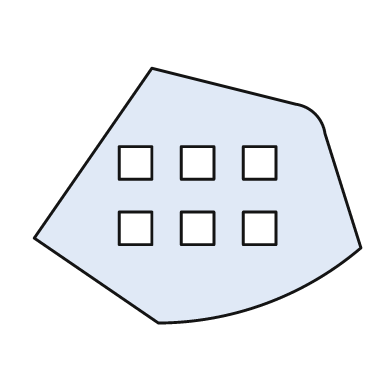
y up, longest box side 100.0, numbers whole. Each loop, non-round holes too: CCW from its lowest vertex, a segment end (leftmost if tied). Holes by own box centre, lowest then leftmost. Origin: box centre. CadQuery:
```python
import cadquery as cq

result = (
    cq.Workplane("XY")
    .moveTo(-12.0, -39.0)
    .threePointArc((21.0, -33.0), (50.0, -16.0))
    .lineTo(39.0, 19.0)
    .threePointArc((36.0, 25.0), (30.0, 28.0))
    .lineTo(-14.0, 39.0)
    .lineTo(-50.0, -13.0)
    .close()
    .moveTo(-24.0, -15.0)
    .lineTo(-14.0, -15.0)
    .lineTo(-14.0, -5.0)
    .lineTo(-24.0, -5.0)
    .close()
    .moveTo(-5.0, -15.0)
    .lineTo(5.0, -15.0)
    .lineTo(5.0, -5.0)
    .lineTo(-5.0, -5.0)
    .close()
    .moveTo(14.0, -15.0)
    .lineTo(24.0, -15.0)
    .lineTo(24.0, -5.0)
    .lineTo(14.0, -5.0)
    .close()
    .moveTo(-24.0, 5.0)
    .lineTo(-14.0, 5.0)
    .lineTo(-14.0, 15.0)
    .lineTo(-24.0, 15.0)
    .close()
    .moveTo(-5.0, 5.0)
    .lineTo(5.0, 5.0)
    .lineTo(5.0, 15.0)
    .lineTo(-5.0, 15.0)
    .close()
    .moveTo(14.0, 5.0)
    .lineTo(24.0, 5.0)
    .lineTo(24.0, 15.0)
    .lineTo(14.0, 15.0)
    .close()
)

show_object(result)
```